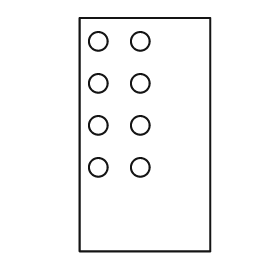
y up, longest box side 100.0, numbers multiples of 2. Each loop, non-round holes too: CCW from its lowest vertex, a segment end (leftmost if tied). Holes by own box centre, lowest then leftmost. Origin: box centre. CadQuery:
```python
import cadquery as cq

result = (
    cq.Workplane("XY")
    .moveTo(-28.0, -50.0)
    .lineTo(28.0, -50.0)
    .lineTo(28.0, 50.0)
    .lineTo(-28.0, 50.0)
    .close()
    .moveTo(-20.0, -14.0)
    .circle(4.0)
    .moveTo(-2.0, -14.0)
    .circle(4.0)
    .moveTo(-20.0, 4.0)
    .circle(4.0)
    .moveTo(-2.0, 4.0)
    .circle(4.0)
    .moveTo(-20.0, 22.0)
    .circle(4.0)
    .moveTo(-2.0, 22.0)
    .circle(4.0)
    .moveTo(-20.0, 40.0)
    .circle(4.0)
    .moveTo(-2.0, 40.0)
    .circle(4.0)
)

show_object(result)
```